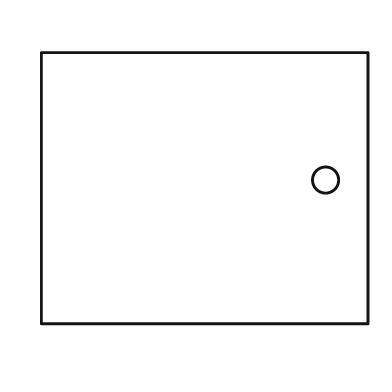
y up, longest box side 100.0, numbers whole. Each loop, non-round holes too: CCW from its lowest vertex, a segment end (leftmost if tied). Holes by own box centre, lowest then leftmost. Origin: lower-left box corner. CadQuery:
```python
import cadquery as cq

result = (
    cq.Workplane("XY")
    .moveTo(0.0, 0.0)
    .lineTo(100.0, 0.0)
    .lineTo(100.0, 83.0)
    .lineTo(0.0, 83.0)
    .close()
    .moveTo(87.0, 44.0)
    .circle(4.0)
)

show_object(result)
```